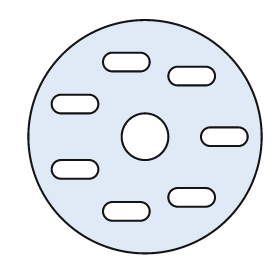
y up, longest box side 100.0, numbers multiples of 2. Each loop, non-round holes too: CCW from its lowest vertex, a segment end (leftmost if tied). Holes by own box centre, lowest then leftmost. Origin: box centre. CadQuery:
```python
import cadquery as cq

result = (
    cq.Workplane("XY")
    .moveTo(0.0, 0.0)
    .circle(50.0)
    .moveTo(-14.0, -36.0)
    .lineTo(-2.0, -36.0)
    .threePointArc((2.0, -32.0), (-2.0, -28.0))
    .lineTo(-14.0, -28.0)
    .threePointArc((-18.0, -32.0), (-14.0, -36.0))
    .close()
    .moveTo(14.0, -30.0)
    .lineTo(26.0, -30.0)
    .threePointArc((30.0, -26.0), (26.0, -22.0))
    .lineTo(14.0, -22.0)
    .threePointArc((10.0, -26.0), (14.0, -30.0))
    .close()
    .moveTo(-36.0, -18.0)
    .lineTo(-24.0, -18.0)
    .threePointArc((-20.0, -14.0), (-24.0, -10.0))
    .lineTo(-36.0, -10.0)
    .threePointArc((-40.0, -14.0), (-36.0, -18.0))
    .close()
    .moveTo(0.0, 0.0)
    .circle(10.0)
    .moveTo(28.0, -4.0)
    .lineTo(40.0, -4.0)
    .threePointArc((44.0, 0.0), (40.0, 4.0))
    .lineTo(28.0, 4.0)
    .threePointArc((24.0, 0.0), (28.0, -4.0))
    .close()
    .moveTo(-36.0, 10.0)
    .lineTo(-24.0, 10.0)
    .threePointArc((-20.0, 14.0), (-24.0, 18.0))
    .lineTo(-36.0, 18.0)
    .threePointArc((-40.0, 14.0), (-36.0, 10.0))
    .close()
    .moveTo(14.0, 22.0)
    .lineTo(26.0, 22.0)
    .threePointArc((30.0, 26.0), (26.0, 30.0))
    .lineTo(14.0, 30.0)
    .threePointArc((10.0, 26.0), (14.0, 22.0))
    .close()
    .moveTo(-14.0, 28.0)
    .lineTo(-2.0, 28.0)
    .threePointArc((2.0, 32.0), (-2.0, 36.0))
    .lineTo(-14.0, 36.0)
    .threePointArc((-18.0, 32.0), (-14.0, 28.0))
    .close()
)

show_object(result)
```